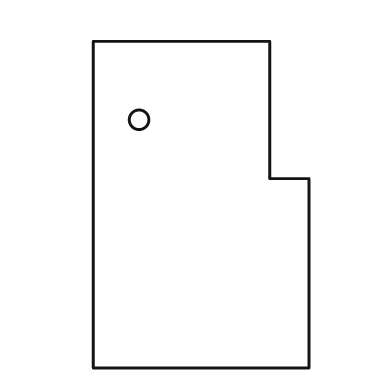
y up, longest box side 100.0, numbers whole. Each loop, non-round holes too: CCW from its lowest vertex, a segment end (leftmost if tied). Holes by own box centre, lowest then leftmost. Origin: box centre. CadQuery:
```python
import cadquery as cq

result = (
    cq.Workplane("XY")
    .moveTo(-33.0, -50.0)
    .lineTo(33.0, -50.0)
    .lineTo(33.0, 8.0)
    .lineTo(21.0, 8.0)
    .lineTo(21.0, 50.0)
    .lineTo(-33.0, 50.0)
    .close()
    .moveTo(-19.0, 26.0)
    .circle(3.0)
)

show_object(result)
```